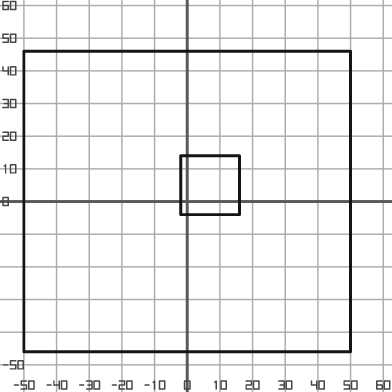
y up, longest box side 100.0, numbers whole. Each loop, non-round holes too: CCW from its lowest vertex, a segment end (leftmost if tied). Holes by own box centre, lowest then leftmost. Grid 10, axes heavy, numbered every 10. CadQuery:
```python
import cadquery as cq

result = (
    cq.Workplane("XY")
    .moveTo(-50.0, -46.0)
    .lineTo(50.0, -46.0)
    .lineTo(50.0, 46.0)
    .lineTo(-50.0, 46.0)
    .close()
    .moveTo(-2.0, -4.0)
    .lineTo(16.0, -4.0)
    .lineTo(16.0, 14.0)
    .lineTo(-2.0, 14.0)
    .close()
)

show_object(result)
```